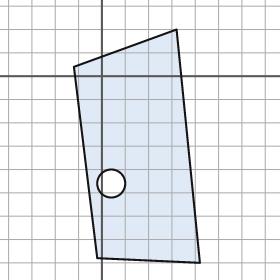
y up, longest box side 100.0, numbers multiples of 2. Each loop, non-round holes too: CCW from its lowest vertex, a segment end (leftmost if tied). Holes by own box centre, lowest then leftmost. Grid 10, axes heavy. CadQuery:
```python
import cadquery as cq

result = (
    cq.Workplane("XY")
    .moveTo(42.0, -80.0)
    .lineTo(32.0, 20.0)
    .lineTo(-12.0, 4.0)
    .lineTo(-2.0, -78.0)
    .close()
    .moveTo(4.0, -46.0)
    .circle(6.0)
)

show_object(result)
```